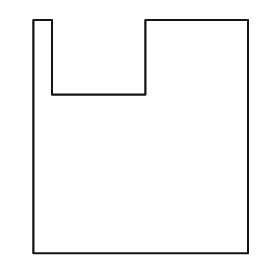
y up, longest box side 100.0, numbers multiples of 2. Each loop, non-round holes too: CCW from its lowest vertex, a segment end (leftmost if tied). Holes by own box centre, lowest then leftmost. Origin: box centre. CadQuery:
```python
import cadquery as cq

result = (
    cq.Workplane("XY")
    .moveTo(-46.0, -50.0)
    .lineTo(46.0, -50.0)
    .lineTo(46.0, 50.0)
    .lineTo(2.0, 50.0)
    .lineTo(2.0, 18.0)
    .lineTo(-38.0, 18.0)
    .lineTo(-38.0, 50.0)
    .lineTo(-46.0, 50.0)
    .close()
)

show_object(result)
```